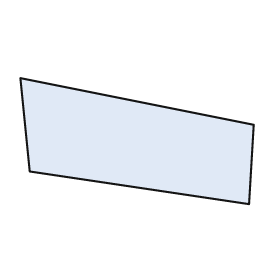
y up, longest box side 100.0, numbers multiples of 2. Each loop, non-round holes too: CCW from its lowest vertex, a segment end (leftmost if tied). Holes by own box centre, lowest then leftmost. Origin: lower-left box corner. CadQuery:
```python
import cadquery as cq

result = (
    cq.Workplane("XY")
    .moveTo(98.0, 0.0)
    .lineTo(100.0, 34.0)
    .lineTo(0.0, 54.0)
    .lineTo(4.0, 14.0)
    .close()
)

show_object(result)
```